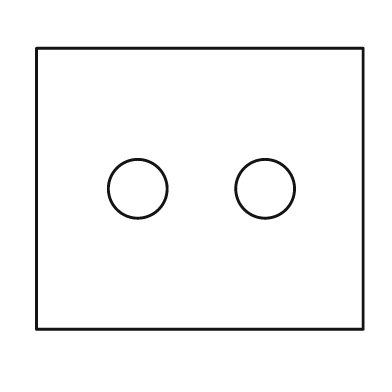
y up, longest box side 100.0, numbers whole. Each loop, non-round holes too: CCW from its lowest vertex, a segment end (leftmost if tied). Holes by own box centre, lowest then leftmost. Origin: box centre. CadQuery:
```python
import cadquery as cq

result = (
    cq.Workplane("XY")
    .moveTo(-50.0, -43.0)
    .lineTo(50.0, -43.0)
    .lineTo(50.0, 43.0)
    .lineTo(-50.0, 43.0)
    .close()
    .moveTo(-19.0, 0.0)
    .circle(9.0)
    .moveTo(20.0, 0.0)
    .circle(9.0)
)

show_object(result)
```